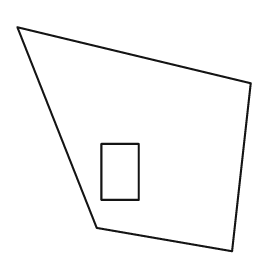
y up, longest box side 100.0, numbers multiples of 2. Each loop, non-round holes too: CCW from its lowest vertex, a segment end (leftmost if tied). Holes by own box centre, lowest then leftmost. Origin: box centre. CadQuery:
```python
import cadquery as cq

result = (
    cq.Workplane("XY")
    .moveTo(42.0, -48.0)
    .lineTo(50.0, 24.0)
    .lineTo(-50.0, 48.0)
    .lineTo(-16.0, -38.0)
    .close()
    .moveTo(-14.0, -26.0)
    .lineTo(2.0, -26.0)
    .lineTo(2.0, -2.0)
    .lineTo(-14.0, -2.0)
    .close()
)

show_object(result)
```